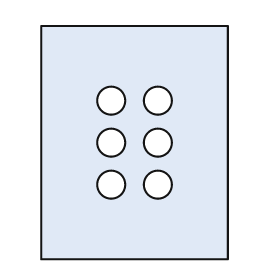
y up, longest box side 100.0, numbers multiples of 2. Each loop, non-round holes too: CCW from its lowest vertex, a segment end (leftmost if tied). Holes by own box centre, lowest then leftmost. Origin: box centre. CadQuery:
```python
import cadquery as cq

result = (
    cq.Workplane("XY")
    .moveTo(-40.0, -50.0)
    .lineTo(40.0, -50.0)
    .lineTo(40.0, 50.0)
    .lineTo(-40.0, 50.0)
    .close()
    .moveTo(-10.0, -18.0)
    .circle(6.0)
    .moveTo(10.0, -18.0)
    .circle(6.0)
    .moveTo(-10.0, 0.0)
    .circle(6.0)
    .moveTo(10.0, 0.0)
    .circle(6.0)
    .moveTo(-10.0, 18.0)
    .circle(6.0)
    .moveTo(10.0, 18.0)
    .circle(6.0)
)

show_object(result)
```